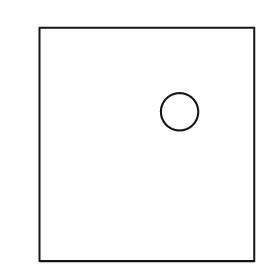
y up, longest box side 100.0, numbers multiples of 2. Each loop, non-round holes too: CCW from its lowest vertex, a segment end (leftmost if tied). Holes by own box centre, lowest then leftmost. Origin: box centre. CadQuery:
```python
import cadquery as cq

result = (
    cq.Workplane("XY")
    .moveTo(-46.0, -50.0)
    .lineTo(46.0, -50.0)
    .lineTo(46.0, 50.0)
    .lineTo(-46.0, 50.0)
    .close()
    .moveTo(14.0, 14.0)
    .circle(8.0)
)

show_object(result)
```